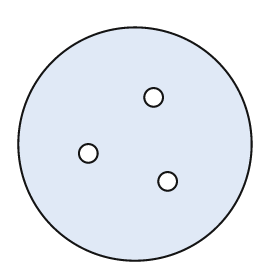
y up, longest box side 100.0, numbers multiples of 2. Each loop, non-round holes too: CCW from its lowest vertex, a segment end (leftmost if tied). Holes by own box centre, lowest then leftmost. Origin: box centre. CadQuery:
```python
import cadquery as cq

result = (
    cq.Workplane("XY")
    .moveTo(0.0, 0.0)
    .circle(50.0)
    .moveTo(14.0, -16.0)
    .circle(4.0)
    .moveTo(-20.0, -4.0)
    .circle(4.0)
    .moveTo(8.0, 20.0)
    .circle(4.0)
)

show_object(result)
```